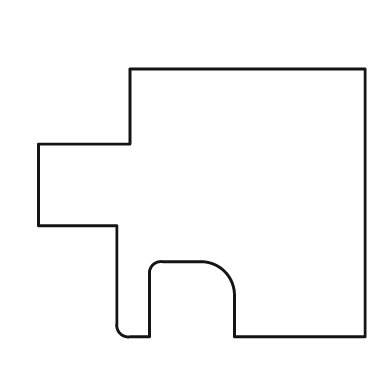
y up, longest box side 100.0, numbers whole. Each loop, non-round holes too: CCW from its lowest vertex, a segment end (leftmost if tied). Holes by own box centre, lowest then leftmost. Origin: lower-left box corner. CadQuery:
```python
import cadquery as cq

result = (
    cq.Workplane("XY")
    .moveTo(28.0, 0.0)
    .lineTo(34.0, 0.0)
    .lineTo(34.0, 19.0)
    .threePointArc((35.0, 22.0), (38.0, 23.0))
    .lineTo(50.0, 23.0)
    .threePointArc((57.0, 20.0), (60.0, 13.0))
    .lineTo(60.0, 0.0)
    .lineTo(100.0, 0.0)
    .lineTo(100.0, 82.0)
    .lineTo(28.0, 82.0)
    .lineTo(28.0, 59.0)
    .lineTo(0.0, 59.0)
    .lineTo(0.0, 34.0)
    .lineTo(24.0, 34.0)
    .lineTo(24.0, 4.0)
    .threePointArc((25.0, 1.0), (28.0, 0.0))
    .close()
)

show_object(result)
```